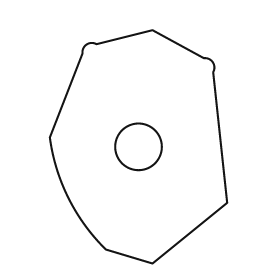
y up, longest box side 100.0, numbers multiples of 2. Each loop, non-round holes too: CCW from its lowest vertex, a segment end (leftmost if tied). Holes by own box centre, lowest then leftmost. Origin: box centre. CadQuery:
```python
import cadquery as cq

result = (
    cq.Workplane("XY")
    .moveTo(6.0, -50.0)
    .lineTo(38.0, -24.0)
    .lineTo(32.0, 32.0)
    .threePointArc((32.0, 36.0), (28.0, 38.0))
    .lineTo(6.0, 50.0)
    .lineTo(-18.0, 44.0)
    .threePointArc((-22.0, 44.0), (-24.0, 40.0))
    .lineTo(-38.0, 4.0)
    .threePointArc((-30.0, -22.0), (-14.0, -44.0))
    .close()
    .moveTo(0.0, 0.0)
    .circle(10.0)
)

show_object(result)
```